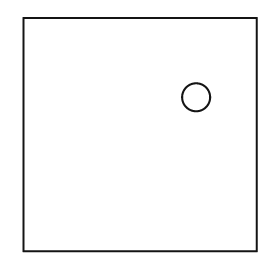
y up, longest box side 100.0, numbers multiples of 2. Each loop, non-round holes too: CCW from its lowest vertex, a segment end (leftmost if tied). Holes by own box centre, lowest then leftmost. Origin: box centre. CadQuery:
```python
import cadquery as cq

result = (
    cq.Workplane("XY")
    .moveTo(-50.0, -50.0)
    .lineTo(50.0, -50.0)
    .lineTo(50.0, 50.0)
    .lineTo(-50.0, 50.0)
    .close()
    .moveTo(24.0, 16.0)
    .circle(6.0)
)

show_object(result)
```